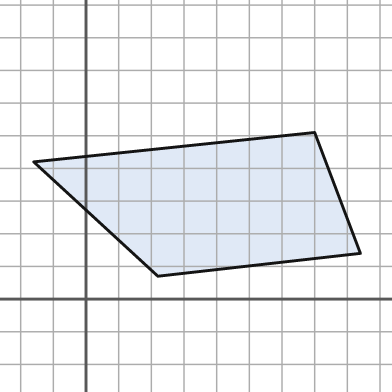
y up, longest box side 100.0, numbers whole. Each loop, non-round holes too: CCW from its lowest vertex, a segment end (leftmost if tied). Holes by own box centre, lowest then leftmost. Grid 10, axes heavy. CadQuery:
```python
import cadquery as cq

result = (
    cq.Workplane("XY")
    .moveTo(22.0, 7.0)
    .lineTo(84.0, 14.0)
    .lineTo(70.0, 51.0)
    .lineTo(-16.0, 42.0)
    .close()
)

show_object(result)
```